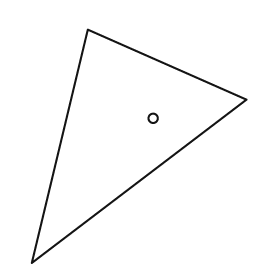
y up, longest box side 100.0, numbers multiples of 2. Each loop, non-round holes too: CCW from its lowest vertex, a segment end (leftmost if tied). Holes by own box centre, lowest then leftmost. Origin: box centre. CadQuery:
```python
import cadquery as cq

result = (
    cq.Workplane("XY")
    .moveTo(-46.0, -50.0)
    .lineTo(46.0, 20.0)
    .lineTo(-22.0, 50.0)
    .close()
    .moveTo(6.0, 12.0)
    .circle(2.0)
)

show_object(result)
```